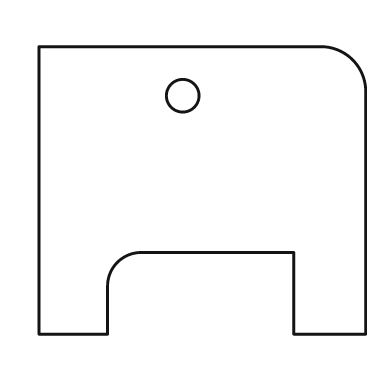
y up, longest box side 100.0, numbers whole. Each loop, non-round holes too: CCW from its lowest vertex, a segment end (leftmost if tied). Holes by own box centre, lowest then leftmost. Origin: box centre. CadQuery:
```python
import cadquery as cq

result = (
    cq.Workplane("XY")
    .moveTo(-50.0, -44.0)
    .lineTo(-29.0, -44.0)
    .lineTo(-29.0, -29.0)
    .threePointArc((-26.0, -22.0), (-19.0, -19.0))
    .lineTo(28.0, -19.0)
    .lineTo(28.0, -44.0)
    .lineTo(50.0, -44.0)
    .lineTo(50.0, 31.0)
    .threePointArc((46.0, 40.0), (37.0, 44.0))
    .lineTo(-50.0, 44.0)
    .close()
    .moveTo(-6.0, 29.0)
    .circle(5.0)
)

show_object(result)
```